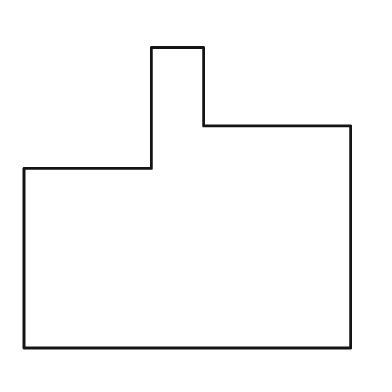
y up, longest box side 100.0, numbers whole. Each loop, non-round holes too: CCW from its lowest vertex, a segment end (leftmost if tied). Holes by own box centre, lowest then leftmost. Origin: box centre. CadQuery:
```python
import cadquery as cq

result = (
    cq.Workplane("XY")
    .moveTo(-50.0, -46.0)
    .lineTo(50.0, -46.0)
    .lineTo(50.0, 22.0)
    .lineTo(5.0, 22.0)
    .lineTo(5.0, 46.0)
    .lineTo(-11.0, 46.0)
    .lineTo(-11.0, 9.0)
    .lineTo(-50.0, 9.0)
    .close()
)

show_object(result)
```